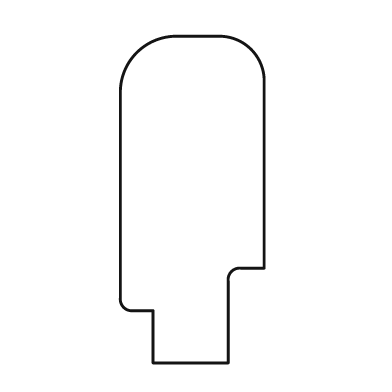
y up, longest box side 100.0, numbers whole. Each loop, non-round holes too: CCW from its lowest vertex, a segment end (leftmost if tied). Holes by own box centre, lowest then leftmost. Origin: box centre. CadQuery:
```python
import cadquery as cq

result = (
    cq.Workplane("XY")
    .moveTo(-12.0, -50.0)
    .lineTo(11.0, -50.0)
    .lineTo(11.0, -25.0)
    .threePointArc((12.0, -22.0), (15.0, -21.0))
    .lineTo(22.0, -21.0)
    .lineTo(22.0, 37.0)
    .threePointArc((18.0, 46.0), (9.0, 50.0))
    .lineTo(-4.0, 50.0)
    .threePointArc((-17.0, 45.0), (-22.0, 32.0))
    .lineTo(-22.0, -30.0)
    .threePointArc((-21.0, -33.0), (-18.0, -34.0))
    .lineTo(-12.0, -34.0)
    .close()
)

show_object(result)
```